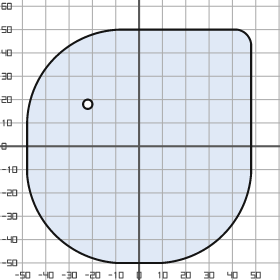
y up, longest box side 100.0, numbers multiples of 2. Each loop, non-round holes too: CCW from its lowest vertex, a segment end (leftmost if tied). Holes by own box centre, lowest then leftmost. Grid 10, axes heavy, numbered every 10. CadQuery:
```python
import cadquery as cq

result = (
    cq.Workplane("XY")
    .moveTo(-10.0, -50.0)
    .lineTo(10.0, -50.0)
    .threePointArc((36.0, -38.0), (48.0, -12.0))
    .lineTo(48.0, 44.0)
    .threePointArc((46.0, 48.0), (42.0, 50.0))
    .lineTo(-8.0, 50.0)
    .threePointArc((-36.0, 38.0), (-48.0, 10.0))
    .lineTo(-48.0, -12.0)
    .threePointArc((-36.0, -38.0), (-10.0, -50.0))
    .close()
    .moveTo(-22.0, 18.0)
    .circle(2.0)
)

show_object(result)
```